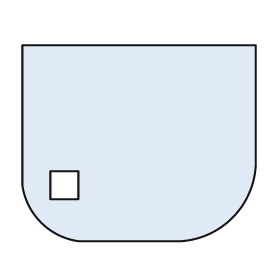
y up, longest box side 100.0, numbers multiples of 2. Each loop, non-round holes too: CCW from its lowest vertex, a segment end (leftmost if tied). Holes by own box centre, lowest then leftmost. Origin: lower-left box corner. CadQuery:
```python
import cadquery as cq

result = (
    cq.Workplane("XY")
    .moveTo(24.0, 0.0)
    .lineTo(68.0, 0.0)
    .threePointArc((90.0, 10.0), (100.0, 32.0))
    .lineTo(100.0, 84.0)
    .lineTo(0.0, 84.0)
    .lineTo(0.0, 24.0)
    .threePointArc((8.0, 8.0), (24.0, 0.0))
    .close()
    .moveTo(12.0, 18.0)
    .lineTo(24.0, 18.0)
    .lineTo(24.0, 30.0)
    .lineTo(12.0, 30.0)
    .close()
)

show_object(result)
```